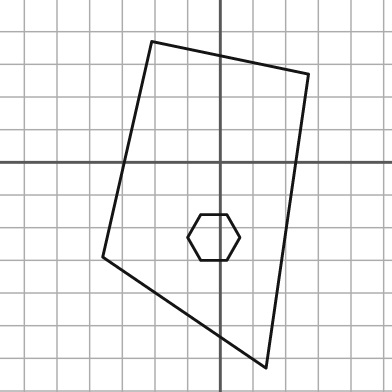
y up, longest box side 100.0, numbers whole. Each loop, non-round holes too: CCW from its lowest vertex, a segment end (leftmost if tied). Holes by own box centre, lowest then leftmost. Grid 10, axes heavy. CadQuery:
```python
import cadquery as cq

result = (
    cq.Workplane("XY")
    .moveTo(14.0, -63.0)
    .lineTo(27.0, 27.0)
    .lineTo(-21.0, 37.0)
    .lineTo(-36.0, -29.0)
    .close()
    .moveTo(-6.0, -30.0)
    .lineTo(2.0, -30.0)
    .lineTo(6.0, -23.0)
    .lineTo(2.0, -16.0)
    .lineTo(-6.0, -16.0)
    .lineTo(-10.0, -23.0)
    .close()
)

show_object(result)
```